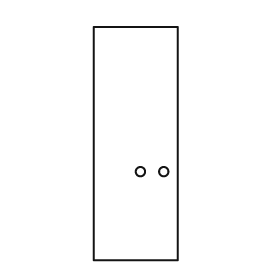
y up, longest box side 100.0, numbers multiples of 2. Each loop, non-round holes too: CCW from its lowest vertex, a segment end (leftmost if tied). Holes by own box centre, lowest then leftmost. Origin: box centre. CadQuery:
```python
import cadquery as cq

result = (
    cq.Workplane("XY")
    .moveTo(-18.0, -50.0)
    .lineTo(18.0, -50.0)
    .lineTo(18.0, 50.0)
    .lineTo(-18.0, 50.0)
    .close()
    .moveTo(2.0, -12.0)
    .circle(2.0)
    .moveTo(12.0, -12.0)
    .circle(2.0)
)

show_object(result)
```